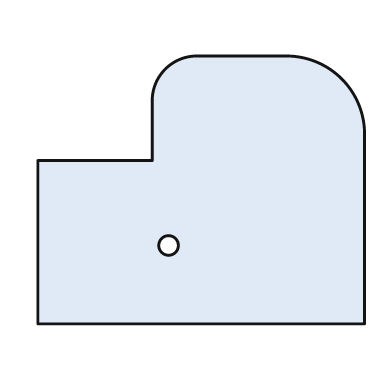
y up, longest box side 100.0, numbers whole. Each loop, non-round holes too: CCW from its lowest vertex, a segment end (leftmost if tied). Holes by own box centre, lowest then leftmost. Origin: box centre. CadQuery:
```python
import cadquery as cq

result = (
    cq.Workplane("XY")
    .moveTo(-50.0, -41.0)
    .lineTo(50.0, -41.0)
    .lineTo(50.0, 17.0)
    .threePointArc((43.0, 34.0), (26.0, 41.0))
    .lineTo(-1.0, 41.0)
    .threePointArc((-11.0, 37.0), (-15.0, 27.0))
    .lineTo(-15.0, 9.0)
    .lineTo(-50.0, 9.0)
    .close()
    .moveTo(-10.0, -17.0)
    .circle(3.0)
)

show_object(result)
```